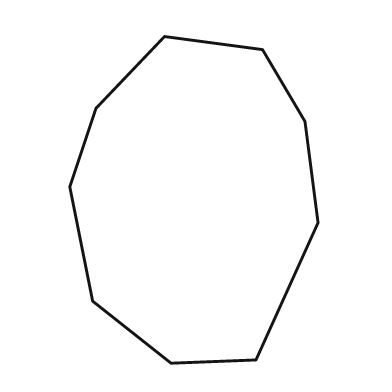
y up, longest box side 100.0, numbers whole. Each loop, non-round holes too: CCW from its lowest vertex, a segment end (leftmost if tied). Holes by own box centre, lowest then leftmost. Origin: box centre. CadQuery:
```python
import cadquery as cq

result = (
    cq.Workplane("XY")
    .moveTo(-7.0, -50.0)
    .lineTo(19.0, -49.0)
    .lineTo(38.0, -7.0)
    .lineTo(34.0, 24.0)
    .lineTo(21.0, 46.0)
    .lineTo(-9.0, 50.0)
    .lineTo(-30.0, 28.0)
    .lineTo(-38.0, 4.0)
    .lineTo(-31.0, -31.0)
    .close()
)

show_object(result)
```